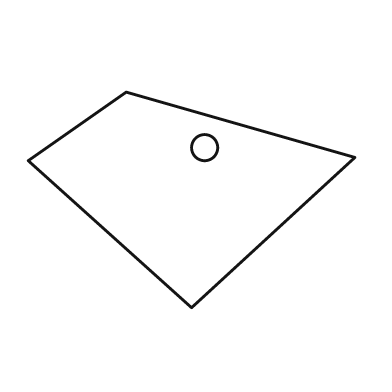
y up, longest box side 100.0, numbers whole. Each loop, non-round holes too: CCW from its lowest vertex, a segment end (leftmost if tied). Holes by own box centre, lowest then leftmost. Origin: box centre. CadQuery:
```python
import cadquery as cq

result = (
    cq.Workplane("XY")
    .moveTo(0.0, -33.0)
    .lineTo(50.0, 13.0)
    .lineTo(-20.0, 33.0)
    .lineTo(-50.0, 12.0)
    .close()
    .moveTo(4.0, 16.0)
    .circle(4.0)
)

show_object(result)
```